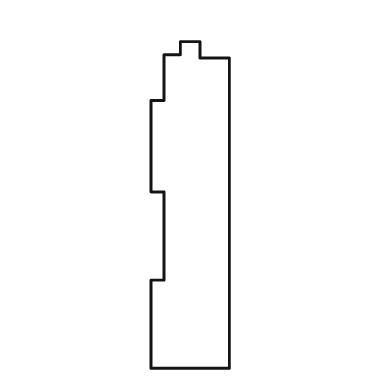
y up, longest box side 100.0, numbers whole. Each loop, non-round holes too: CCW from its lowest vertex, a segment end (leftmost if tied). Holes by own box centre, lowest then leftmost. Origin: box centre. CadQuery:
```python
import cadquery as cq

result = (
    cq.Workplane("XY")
    .moveTo(-12.0, -50.0)
    .lineTo(12.0, -50.0)
    .lineTo(12.0, 45.0)
    .lineTo(3.0, 45.0)
    .lineTo(3.0, 50.0)
    .lineTo(-3.0, 50.0)
    .lineTo(-3.0, 46.0)
    .lineTo(-8.0, 46.0)
    .lineTo(-8.0, 32.0)
    .lineTo(-12.0, 32.0)
    .lineTo(-12.0, 4.0)
    .lineTo(-8.0, 4.0)
    .lineTo(-8.0, -23.0)
    .lineTo(-12.0, -23.0)
    .close()
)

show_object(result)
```